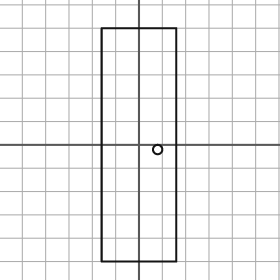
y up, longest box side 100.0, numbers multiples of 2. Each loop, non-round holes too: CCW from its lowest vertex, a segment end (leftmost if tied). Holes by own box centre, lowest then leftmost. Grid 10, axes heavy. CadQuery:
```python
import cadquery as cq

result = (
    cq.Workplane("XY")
    .moveTo(-16.0, -50.0)
    .lineTo(16.0, -50.0)
    .lineTo(16.0, 50.0)
    .lineTo(-16.0, 50.0)
    .close()
    .moveTo(8.0, -2.0)
    .circle(2.0)
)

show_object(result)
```